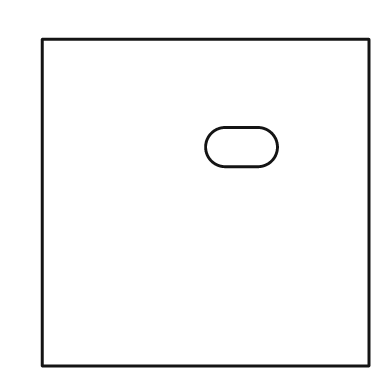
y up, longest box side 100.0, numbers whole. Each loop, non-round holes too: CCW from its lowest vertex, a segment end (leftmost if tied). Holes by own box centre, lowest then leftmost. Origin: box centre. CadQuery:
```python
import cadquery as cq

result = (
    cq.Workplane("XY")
    .moveTo(-50.0, -50.0)
    .lineTo(50.0, -50.0)
    .lineTo(50.0, 50.0)
    .lineTo(-50.0, 50.0)
    .close()
    .moveTo(6.0, 11.0)
    .lineTo(16.0, 11.0)
    .threePointArc((22.0, 17.0), (16.0, 23.0))
    .lineTo(6.0, 23.0)
    .threePointArc((0.0, 17.0), (6.0, 11.0))
    .close()
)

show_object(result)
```